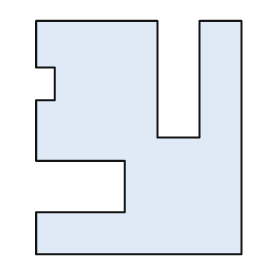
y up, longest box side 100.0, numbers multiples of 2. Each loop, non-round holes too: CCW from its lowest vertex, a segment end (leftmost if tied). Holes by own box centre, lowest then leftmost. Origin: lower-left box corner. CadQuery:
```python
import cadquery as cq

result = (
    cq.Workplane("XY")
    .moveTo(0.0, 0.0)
    .lineTo(88.0, 0.0)
    .lineTo(88.0, 100.0)
    .lineTo(70.0, 100.0)
    .lineTo(70.0, 50.0)
    .lineTo(52.0, 50.0)
    .lineTo(52.0, 100.0)
    .lineTo(0.0, 100.0)
    .lineTo(0.0, 80.0)
    .lineTo(8.0, 80.0)
    .lineTo(8.0, 66.0)
    .lineTo(0.0, 66.0)
    .lineTo(0.0, 40.0)
    .lineTo(38.0, 40.0)
    .lineTo(38.0, 18.0)
    .lineTo(0.0, 18.0)
    .close()
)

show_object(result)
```